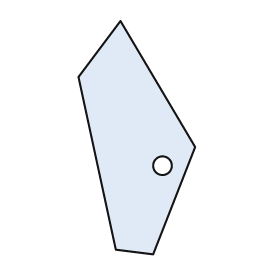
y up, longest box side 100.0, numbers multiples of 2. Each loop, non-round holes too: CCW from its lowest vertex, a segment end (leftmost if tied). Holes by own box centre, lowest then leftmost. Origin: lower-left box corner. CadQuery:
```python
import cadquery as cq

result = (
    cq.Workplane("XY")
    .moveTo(32.0, 0.0)
    .lineTo(50.0, 46.0)
    .lineTo(18.0, 100.0)
    .lineTo(0.0, 76.0)
    .lineTo(16.0, 2.0)
    .close()
    .moveTo(36.0, 38.0)
    .circle(4.0)
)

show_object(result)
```